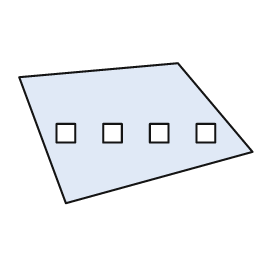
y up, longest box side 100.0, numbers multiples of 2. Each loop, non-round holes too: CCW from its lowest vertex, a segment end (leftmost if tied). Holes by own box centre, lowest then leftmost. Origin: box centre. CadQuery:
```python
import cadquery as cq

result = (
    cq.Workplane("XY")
    .moveTo(-30.0, -30.0)
    .lineTo(50.0, -8.0)
    .lineTo(18.0, 30.0)
    .lineTo(-50.0, 24.0)
    .close()
    .moveTo(-34.0, -4.0)
    .lineTo(-26.0, -4.0)
    .lineTo(-26.0, 4.0)
    .lineTo(-34.0, 4.0)
    .close()
    .moveTo(-14.0, -4.0)
    .lineTo(-6.0, -4.0)
    .lineTo(-6.0, 4.0)
    .lineTo(-14.0, 4.0)
    .close()
    .moveTo(6.0, -4.0)
    .lineTo(14.0, -4.0)
    .lineTo(14.0, 4.0)
    .lineTo(6.0, 4.0)
    .close()
    .moveTo(26.0, -4.0)
    .lineTo(34.0, -4.0)
    .lineTo(34.0, 4.0)
    .lineTo(26.0, 4.0)
    .close()
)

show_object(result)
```